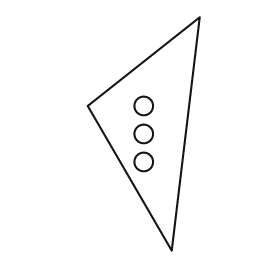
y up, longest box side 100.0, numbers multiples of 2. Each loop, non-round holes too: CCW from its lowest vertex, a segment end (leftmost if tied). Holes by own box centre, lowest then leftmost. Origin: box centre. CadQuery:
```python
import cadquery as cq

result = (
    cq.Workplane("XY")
    .moveTo(12.0, -50.0)
    .lineTo(24.0, 50.0)
    .lineTo(-24.0, 12.0)
    .close()
    .moveTo(0.0, -12.0)
    .circle(4.0)
    .moveTo(0.0, 0.0)
    .circle(4.0)
    .moveTo(0.0, 12.0)
    .circle(4.0)
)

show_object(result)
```